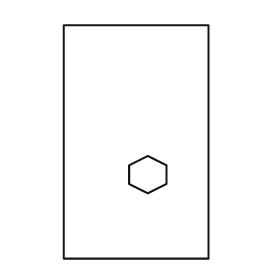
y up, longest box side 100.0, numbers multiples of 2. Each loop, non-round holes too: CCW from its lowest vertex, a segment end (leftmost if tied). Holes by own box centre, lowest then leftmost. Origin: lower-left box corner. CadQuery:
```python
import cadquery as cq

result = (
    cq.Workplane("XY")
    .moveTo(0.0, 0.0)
    .lineTo(62.0, 0.0)
    .lineTo(62.0, 100.0)
    .lineTo(0.0, 100.0)
    .close()
    .moveTo(36.0, 28.0)
    .lineTo(44.0, 32.0)
    .lineTo(44.0, 40.0)
    .lineTo(36.0, 44.0)
    .lineTo(28.0, 40.0)
    .lineTo(28.0, 32.0)
    .close()
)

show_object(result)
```